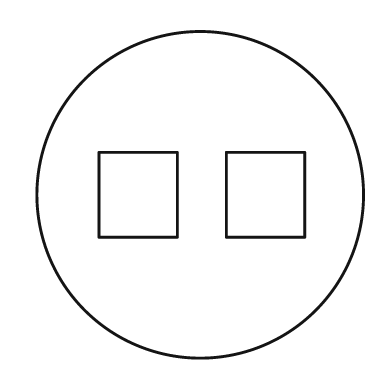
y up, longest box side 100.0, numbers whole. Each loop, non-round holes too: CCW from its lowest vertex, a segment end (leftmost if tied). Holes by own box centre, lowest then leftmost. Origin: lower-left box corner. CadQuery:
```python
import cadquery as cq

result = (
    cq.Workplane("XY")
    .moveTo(50.0, 50.0)
    .circle(50.0)
    .moveTo(19.0, 37.0)
    .lineTo(43.0, 37.0)
    .lineTo(43.0, 63.0)
    .lineTo(19.0, 63.0)
    .close()
    .moveTo(58.0, 37.0)
    .lineTo(82.0, 37.0)
    .lineTo(82.0, 63.0)
    .lineTo(58.0, 63.0)
    .close()
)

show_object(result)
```